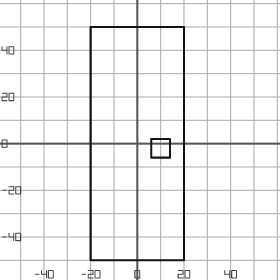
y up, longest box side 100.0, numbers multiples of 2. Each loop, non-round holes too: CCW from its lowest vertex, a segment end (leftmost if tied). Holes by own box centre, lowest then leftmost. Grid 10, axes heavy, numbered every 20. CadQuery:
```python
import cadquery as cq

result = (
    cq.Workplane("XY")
    .moveTo(-20.0, -50.0)
    .lineTo(20.0, -50.0)
    .lineTo(20.0, 50.0)
    .lineTo(-20.0, 50.0)
    .close()
    .moveTo(6.0, -6.0)
    .lineTo(14.0, -6.0)
    .lineTo(14.0, 2.0)
    .lineTo(6.0, 2.0)
    .close()
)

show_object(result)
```